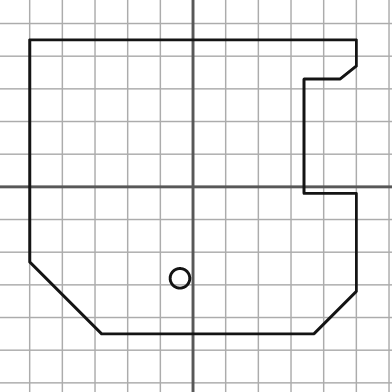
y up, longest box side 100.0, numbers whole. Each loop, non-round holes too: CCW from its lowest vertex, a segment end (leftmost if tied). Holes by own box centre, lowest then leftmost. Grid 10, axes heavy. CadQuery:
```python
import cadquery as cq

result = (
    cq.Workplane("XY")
    .moveTo(-28.0, -45.0)
    .lineTo(37.0, -45.0)
    .lineTo(50.0, -32.0)
    .lineTo(50.0, -2.0)
    .lineTo(34.0, -2.0)
    .lineTo(34.0, 33.0)
    .lineTo(45.0, 33.0)
    .lineTo(50.0, 37.0)
    .lineTo(50.0, 45.0)
    .lineTo(-50.0, 45.0)
    .lineTo(-50.0, -23.0)
    .close()
    .moveTo(-4.0, -28.0)
    .circle(3.0)
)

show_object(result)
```